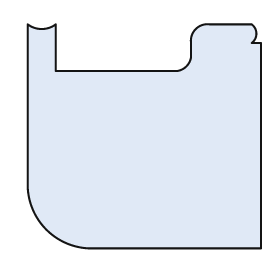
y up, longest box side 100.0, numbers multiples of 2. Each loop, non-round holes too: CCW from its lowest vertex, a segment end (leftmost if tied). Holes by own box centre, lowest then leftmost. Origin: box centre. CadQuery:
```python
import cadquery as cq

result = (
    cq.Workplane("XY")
    .moveTo(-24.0, -48.0)
    .lineTo(50.0, -48.0)
    .lineTo(50.0, 40.0)
    .lineTo(46.0, 40.0)
    .threePointArc((48.0, 44.0), (46.0, 48.0))
    .lineTo(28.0, 48.0)
    .threePointArc((22.0, 46.0), (20.0, 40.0))
    .lineTo(20.0, 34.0)
    .threePointArc((18.0, 30.0), (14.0, 28.0))
    .lineTo(-38.0, 28.0)
    .lineTo(-38.0, 48.0)
    .threePointArc((-44.0, 46.0), (-50.0, 48.0))
    .lineTo(-50.0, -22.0)
    .threePointArc((-42.0, -40.0), (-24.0, -48.0))
    .close()
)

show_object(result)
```